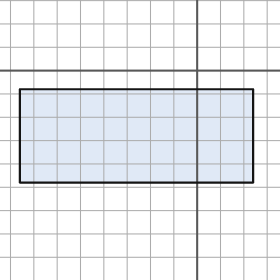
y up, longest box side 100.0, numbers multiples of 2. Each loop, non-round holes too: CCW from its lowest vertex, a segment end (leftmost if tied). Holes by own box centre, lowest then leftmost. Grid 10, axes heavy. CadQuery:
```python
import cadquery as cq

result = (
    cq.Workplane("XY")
    .moveTo(-76.0, -48.0)
    .lineTo(24.0, -48.0)
    .lineTo(24.0, -8.0)
    .lineTo(-76.0, -8.0)
    .close()
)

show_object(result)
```